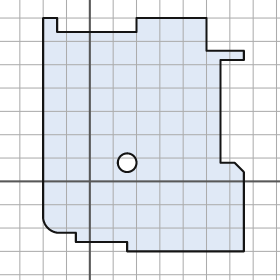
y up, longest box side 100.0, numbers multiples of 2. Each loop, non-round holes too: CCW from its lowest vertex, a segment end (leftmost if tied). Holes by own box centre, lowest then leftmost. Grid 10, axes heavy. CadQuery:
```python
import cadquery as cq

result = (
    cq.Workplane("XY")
    .moveTo(16.0, -30.0)
    .lineTo(66.0, -30.0)
    .lineTo(66.0, 4.0)
    .lineTo(62.0, 8.0)
    .lineTo(56.0, 8.0)
    .lineTo(56.0, 52.0)
    .lineTo(66.0, 52.0)
    .lineTo(66.0, 56.0)
    .lineTo(50.0, 56.0)
    .lineTo(50.0, 70.0)
    .lineTo(20.0, 70.0)
    .lineTo(20.0, 64.0)
    .lineTo(-14.0, 64.0)
    .lineTo(-14.0, 70.0)
    .lineTo(-20.0, 70.0)
    .lineTo(-20.0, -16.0)
    .threePointArc((-18.0, -20.0), (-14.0, -22.0))
    .lineTo(-6.0, -22.0)
    .lineTo(-6.0, -26.0)
    .lineTo(16.0, -26.0)
    .close()
    .moveTo(16.0, 8.0)
    .circle(4.0)
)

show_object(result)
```